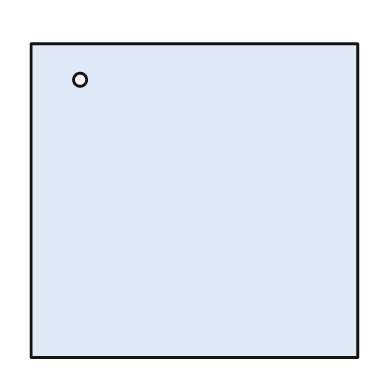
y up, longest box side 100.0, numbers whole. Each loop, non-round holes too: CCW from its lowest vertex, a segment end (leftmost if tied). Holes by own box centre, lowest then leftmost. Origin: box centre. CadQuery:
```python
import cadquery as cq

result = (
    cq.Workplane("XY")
    .moveTo(-50.0, -48.0)
    .lineTo(50.0, -48.0)
    .lineTo(50.0, 48.0)
    .lineTo(-50.0, 48.0)
    .close()
    .moveTo(-35.0, 37.0)
    .circle(2.0)
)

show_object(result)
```